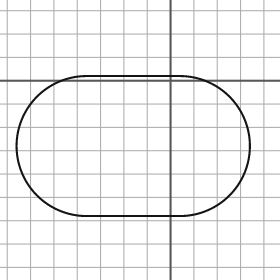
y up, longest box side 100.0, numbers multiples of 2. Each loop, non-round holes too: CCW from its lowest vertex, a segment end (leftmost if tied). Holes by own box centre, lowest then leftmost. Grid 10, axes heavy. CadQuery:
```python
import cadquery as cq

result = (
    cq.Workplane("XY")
    .moveTo(-36.0, -58.0)
    .lineTo(4.0, -58.0)
    .threePointArc((34.0, -28.0), (4.0, 2.0))
    .lineTo(-36.0, 2.0)
    .threePointArc((-66.0, -28.0), (-36.0, -58.0))
    .close()
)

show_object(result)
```